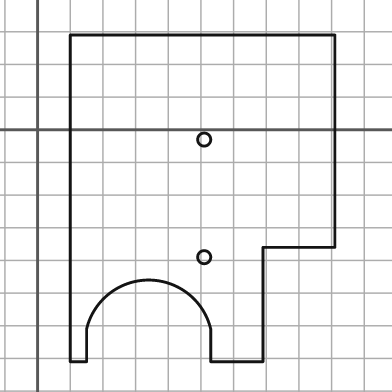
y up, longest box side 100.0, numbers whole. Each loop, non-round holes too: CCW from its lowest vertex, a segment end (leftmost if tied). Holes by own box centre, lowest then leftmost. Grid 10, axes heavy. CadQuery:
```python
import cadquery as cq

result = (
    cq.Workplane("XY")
    .moveTo(10.0, -71.0)
    .lineTo(15.0, -71.0)
    .lineTo(15.0, -61.0)
    .threePointArc((34.0, -46.0), (53.0, -61.0))
    .lineTo(53.0, -71.0)
    .lineTo(69.0, -71.0)
    .lineTo(69.0, -36.0)
    .lineTo(91.0, -36.0)
    .lineTo(91.0, 29.0)
    .lineTo(10.0, 29.0)
    .close()
    .moveTo(51.0, -39.0)
    .circle(2.0)
    .moveTo(51.0, -3.0)
    .circle(2.0)
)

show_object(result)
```